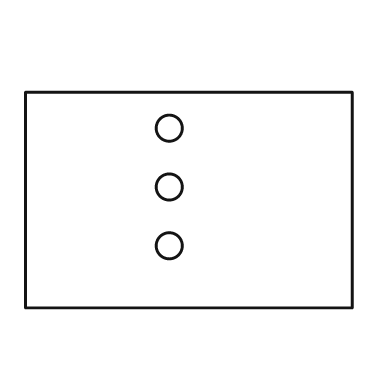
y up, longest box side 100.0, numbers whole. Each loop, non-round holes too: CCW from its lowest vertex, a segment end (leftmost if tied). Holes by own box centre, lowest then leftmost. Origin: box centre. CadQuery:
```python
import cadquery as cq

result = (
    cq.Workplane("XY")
    .moveTo(-50.0, -33.0)
    .lineTo(50.0, -33.0)
    .lineTo(50.0, 33.0)
    .lineTo(-50.0, 33.0)
    .close()
    .moveTo(-6.0, -14.0)
    .circle(4.0)
    .moveTo(-6.0, 4.0)
    .circle(4.0)
    .moveTo(-6.0, 22.0)
    .circle(4.0)
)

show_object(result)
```